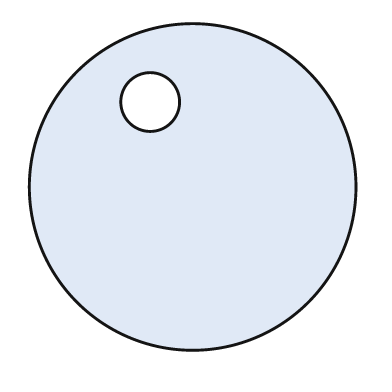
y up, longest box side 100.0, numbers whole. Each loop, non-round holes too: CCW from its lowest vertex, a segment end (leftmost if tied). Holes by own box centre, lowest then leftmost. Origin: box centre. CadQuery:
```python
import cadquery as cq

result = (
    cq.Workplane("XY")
    .moveTo(0.0, 0.0)
    .circle(50.0)
    .moveTo(-13.0, 26.0)
    .circle(9.0)
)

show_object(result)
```